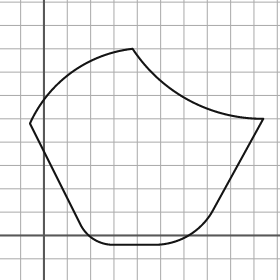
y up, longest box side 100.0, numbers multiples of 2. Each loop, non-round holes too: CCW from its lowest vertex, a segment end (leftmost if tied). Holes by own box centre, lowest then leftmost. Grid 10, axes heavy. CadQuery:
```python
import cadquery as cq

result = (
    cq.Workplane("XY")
    .moveTo(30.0, -4.0)
    .lineTo(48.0, -4.0)
    .threePointArc((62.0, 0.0), (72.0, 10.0))
    .lineTo(94.0, 50.0)
    .threePointArc((62.0, 58.0), (38.0, 80.0))
    .threePointArc((12.0, 70.0), (-6.0, 48.0))
    .lineTo(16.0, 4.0)
    .threePointArc((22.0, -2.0), (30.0, -4.0))
    .close()
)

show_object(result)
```